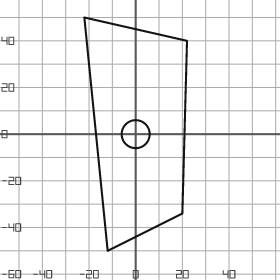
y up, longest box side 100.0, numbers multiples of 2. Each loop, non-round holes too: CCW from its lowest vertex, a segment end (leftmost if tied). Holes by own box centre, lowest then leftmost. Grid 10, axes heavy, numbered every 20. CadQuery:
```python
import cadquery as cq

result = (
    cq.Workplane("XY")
    .moveTo(-12.0, -50.0)
    .lineTo(20.0, -34.0)
    .lineTo(22.0, 40.0)
    .lineTo(-22.0, 50.0)
    .close()
    .moveTo(0.0, 0.0)
    .circle(6.0)
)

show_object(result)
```